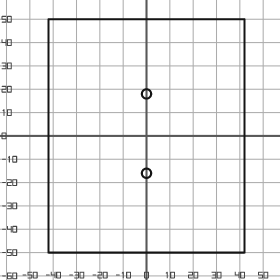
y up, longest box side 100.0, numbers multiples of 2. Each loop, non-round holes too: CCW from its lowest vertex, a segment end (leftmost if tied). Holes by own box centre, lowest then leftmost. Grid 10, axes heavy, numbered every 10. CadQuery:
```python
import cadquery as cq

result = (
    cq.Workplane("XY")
    .moveTo(-42.0, -50.0)
    .lineTo(42.0, -50.0)
    .lineTo(42.0, 50.0)
    .lineTo(-42.0, 50.0)
    .close()
    .moveTo(0.0, -16.0)
    .circle(2.0)
    .moveTo(0.0, 18.0)
    .circle(2.0)
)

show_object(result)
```